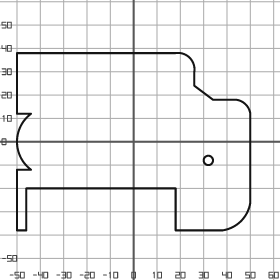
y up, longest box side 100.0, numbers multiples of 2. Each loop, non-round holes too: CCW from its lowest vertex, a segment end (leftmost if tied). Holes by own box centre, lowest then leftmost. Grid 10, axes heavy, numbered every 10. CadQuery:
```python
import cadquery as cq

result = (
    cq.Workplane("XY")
    .moveTo(-50.0, -38.0)
    .lineTo(-46.0, -38.0)
    .lineTo(-46.0, -20.0)
    .lineTo(18.0, -20.0)
    .lineTo(18.0, -38.0)
    .lineTo(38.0, -38.0)
    .threePointArc((46.0, -34.0), (50.0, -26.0))
    .lineTo(50.0, 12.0)
    .threePointArc((48.0, 16.0), (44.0, 18.0))
    .lineTo(34.0, 18.0)
    .lineTo(26.0, 24.0)
    .lineTo(26.0, 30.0)
    .threePointArc((24.0, 36.0), (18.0, 38.0))
    .lineTo(-50.0, 38.0)
    .lineTo(-50.0, 12.0)
    .lineTo(-44.0, 12.0)
    .threePointArc((-50.0, 0.0), (-44.0, -12.0))
    .lineTo(-50.0, -12.0)
    .close()
    .moveTo(32.0, -8.0)
    .circle(2.0)
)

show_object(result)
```